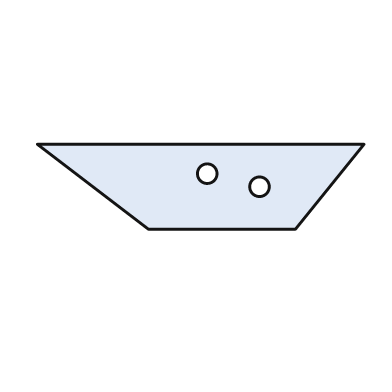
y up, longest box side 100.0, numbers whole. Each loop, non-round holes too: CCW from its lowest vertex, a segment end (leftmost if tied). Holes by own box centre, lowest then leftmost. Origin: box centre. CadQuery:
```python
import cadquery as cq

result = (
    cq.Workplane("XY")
    .moveTo(-16.0, -13.0)
    .lineTo(29.0, -13.0)
    .lineTo(50.0, 13.0)
    .lineTo(-50.0, 13.0)
    .close()
    .moveTo(18.0, 0.0)
    .circle(3.0)
    .moveTo(2.0, 4.0)
    .circle(3.0)
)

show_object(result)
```